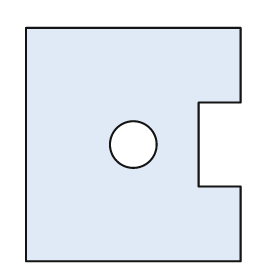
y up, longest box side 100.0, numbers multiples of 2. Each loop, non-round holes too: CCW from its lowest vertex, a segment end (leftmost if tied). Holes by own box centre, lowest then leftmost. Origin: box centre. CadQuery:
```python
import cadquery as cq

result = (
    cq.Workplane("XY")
    .moveTo(-46.0, -50.0)
    .lineTo(46.0, -50.0)
    .lineTo(46.0, -18.0)
    .lineTo(28.0, -18.0)
    .lineTo(28.0, 18.0)
    .lineTo(46.0, 18.0)
    .lineTo(46.0, 50.0)
    .lineTo(-46.0, 50.0)
    .close()
    .moveTo(0.0, 0.0)
    .circle(10.0)
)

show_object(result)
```